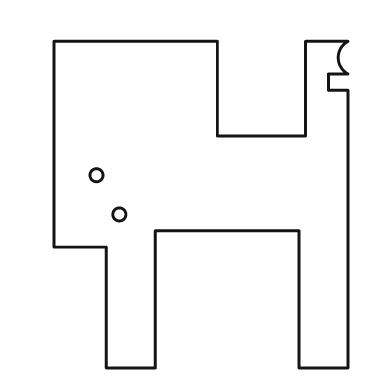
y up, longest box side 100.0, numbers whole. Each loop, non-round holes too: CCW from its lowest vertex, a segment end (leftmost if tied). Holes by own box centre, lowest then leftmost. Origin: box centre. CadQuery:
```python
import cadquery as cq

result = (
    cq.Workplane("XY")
    .moveTo(-29.0, -50.0)
    .lineTo(-14.0, -50.0)
    .lineTo(-14.0, -8.0)
    .lineTo(30.0, -8.0)
    .lineTo(30.0, -50.0)
    .lineTo(45.0, -50.0)
    .lineTo(45.0, 35.0)
    .lineTo(39.0, 35.0)
    .lineTo(39.0, 40.0)
    .lineTo(45.0, 40.0)
    .threePointArc((42.0, 45.0), (45.0, 50.0))
    .lineTo(32.0, 50.0)
    .lineTo(32.0, 21.0)
    .lineTo(5.0, 21.0)
    .lineTo(5.0, 50.0)
    .lineTo(-45.0, 50.0)
    .lineTo(-45.0, -13.0)
    .lineTo(-29.0, -13.0)
    .close()
    .moveTo(-25.0, -3.0)
    .circle(2.0)
    .moveTo(-32.0, 9.0)
    .circle(2.0)
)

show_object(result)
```